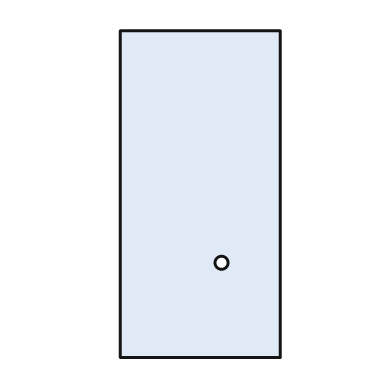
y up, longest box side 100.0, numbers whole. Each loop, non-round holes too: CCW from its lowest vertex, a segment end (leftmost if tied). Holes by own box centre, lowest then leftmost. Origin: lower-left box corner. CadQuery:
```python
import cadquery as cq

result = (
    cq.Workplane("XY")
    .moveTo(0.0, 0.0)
    .lineTo(49.0, 0.0)
    .lineTo(49.0, 100.0)
    .lineTo(0.0, 100.0)
    .close()
    .moveTo(31.0, 29.0)
    .circle(2.0)
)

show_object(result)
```